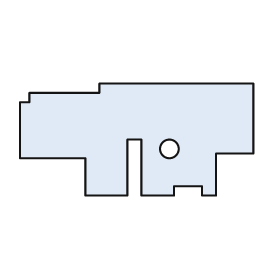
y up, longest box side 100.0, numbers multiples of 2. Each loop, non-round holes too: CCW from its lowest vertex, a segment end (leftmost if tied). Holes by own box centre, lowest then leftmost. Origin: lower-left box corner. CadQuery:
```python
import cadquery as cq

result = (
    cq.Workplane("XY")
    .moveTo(28.0, 0.0)
    .lineTo(46.0, 0.0)
    .lineTo(46.0, 24.0)
    .lineTo(52.0, 24.0)
    .lineTo(52.0, 0.0)
    .lineTo(66.0, 0.0)
    .lineTo(66.0, 4.0)
    .lineTo(78.0, 4.0)
    .lineTo(78.0, 0.0)
    .lineTo(84.0, 0.0)
    .lineTo(84.0, 18.0)
    .lineTo(100.0, 18.0)
    .lineTo(100.0, 48.0)
    .lineTo(34.0, 48.0)
    .lineTo(34.0, 44.0)
    .lineTo(4.0, 44.0)
    .lineTo(4.0, 40.0)
    .lineTo(0.0, 40.0)
    .lineTo(0.0, 16.0)
    .lineTo(28.0, 16.0)
    .close()
    .moveTo(64.0, 20.0)
    .circle(4.0)
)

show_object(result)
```